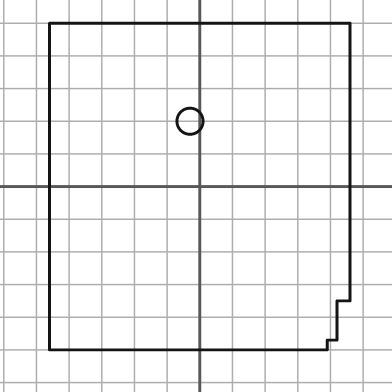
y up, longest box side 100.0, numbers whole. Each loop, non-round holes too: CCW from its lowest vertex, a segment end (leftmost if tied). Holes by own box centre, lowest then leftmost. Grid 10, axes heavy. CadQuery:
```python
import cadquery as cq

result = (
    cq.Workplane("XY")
    .moveTo(-46.0, -50.0)
    .lineTo(39.0, -50.0)
    .lineTo(39.0, -47.0)
    .lineTo(42.0, -47.0)
    .lineTo(42.0, -35.0)
    .lineTo(46.0, -35.0)
    .lineTo(46.0, 50.0)
    .lineTo(-46.0, 50.0)
    .close()
    .moveTo(-3.0, 20.0)
    .circle(4.0)
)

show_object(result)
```